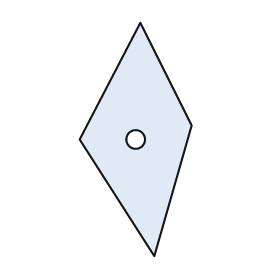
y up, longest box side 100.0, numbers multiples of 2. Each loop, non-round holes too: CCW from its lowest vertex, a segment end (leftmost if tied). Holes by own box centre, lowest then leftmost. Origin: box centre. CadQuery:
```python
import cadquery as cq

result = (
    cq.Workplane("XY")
    .moveTo(8.0, -50.0)
    .lineTo(24.0, 6.0)
    .lineTo(2.0, 50.0)
    .lineTo(-24.0, 0.0)
    .close()
    .moveTo(0.0, 0.0)
    .circle(4.0)
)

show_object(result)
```